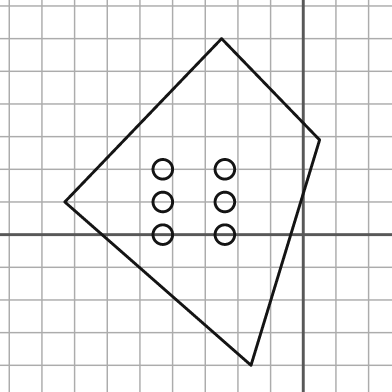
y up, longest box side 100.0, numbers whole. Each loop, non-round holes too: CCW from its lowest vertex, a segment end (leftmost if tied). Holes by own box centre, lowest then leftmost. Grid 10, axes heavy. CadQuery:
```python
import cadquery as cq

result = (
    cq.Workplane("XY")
    .moveTo(-16.0, -40.0)
    .lineTo(5.0, 29.0)
    .lineTo(-25.0, 60.0)
    .lineTo(-73.0, 10.0)
    .close()
    .moveTo(-43.0, 0.0)
    .circle(3.0)
    .moveTo(-24.0, 0.0)
    .circle(3.0)
    .moveTo(-43.0, 10.0)
    .circle(3.0)
    .moveTo(-24.0, 10.0)
    .circle(3.0)
    .moveTo(-43.0, 20.0)
    .circle(3.0)
    .moveTo(-24.0, 20.0)
    .circle(3.0)
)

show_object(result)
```